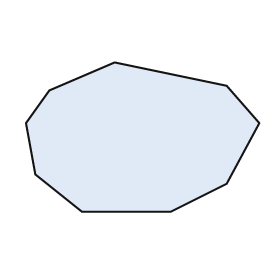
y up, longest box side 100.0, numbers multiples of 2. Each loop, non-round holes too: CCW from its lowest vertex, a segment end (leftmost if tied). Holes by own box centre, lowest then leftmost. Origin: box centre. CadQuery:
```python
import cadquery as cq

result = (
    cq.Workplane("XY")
    .moveTo(-26.0, -32.0)
    .lineTo(12.0, -32.0)
    .lineTo(36.0, -20.0)
    .lineTo(50.0, 6.0)
    .lineTo(36.0, 22.0)
    .lineTo(-12.0, 32.0)
    .lineTo(-40.0, 20.0)
    .lineTo(-50.0, 6.0)
    .lineTo(-46.0, -16.0)
    .close()
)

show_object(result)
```